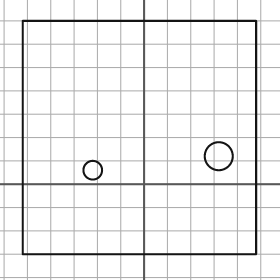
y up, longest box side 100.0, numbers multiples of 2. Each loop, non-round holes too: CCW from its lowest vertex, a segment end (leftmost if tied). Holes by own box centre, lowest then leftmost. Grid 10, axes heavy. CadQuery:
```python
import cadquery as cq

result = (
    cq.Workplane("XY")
    .moveTo(-52.0, -30.0)
    .lineTo(48.0, -30.0)
    .lineTo(48.0, 70.0)
    .lineTo(-52.0, 70.0)
    .close()
    .moveTo(-22.0, 6.0)
    .circle(4.0)
    .moveTo(32.0, 12.0)
    .circle(6.0)
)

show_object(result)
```